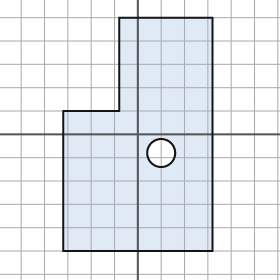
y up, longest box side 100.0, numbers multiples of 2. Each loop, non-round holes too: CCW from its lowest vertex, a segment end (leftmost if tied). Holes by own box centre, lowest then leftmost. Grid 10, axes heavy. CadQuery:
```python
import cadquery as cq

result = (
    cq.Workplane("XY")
    .moveTo(-32.0, -50.0)
    .lineTo(32.0, -50.0)
    .lineTo(32.0, 50.0)
    .lineTo(-8.0, 50.0)
    .lineTo(-8.0, 10.0)
    .lineTo(-32.0, 10.0)
    .close()
    .moveTo(10.0, -8.0)
    .circle(6.0)
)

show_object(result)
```